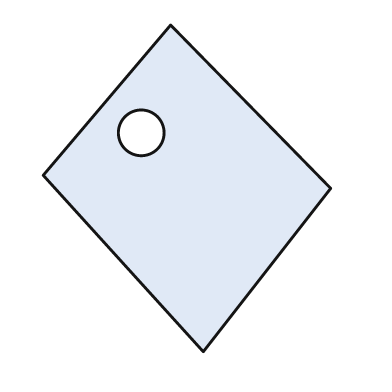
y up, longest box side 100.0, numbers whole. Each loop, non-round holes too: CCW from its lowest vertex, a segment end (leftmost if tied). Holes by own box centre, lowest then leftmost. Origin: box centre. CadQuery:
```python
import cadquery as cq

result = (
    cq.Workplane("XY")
    .moveTo(5.0, -50.0)
    .lineTo(44.0, 0.0)
    .lineTo(-5.0, 50.0)
    .lineTo(-44.0, 4.0)
    .close()
    .moveTo(-14.0, 17.0)
    .circle(7.0)
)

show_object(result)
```